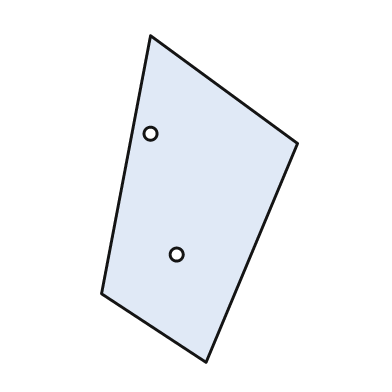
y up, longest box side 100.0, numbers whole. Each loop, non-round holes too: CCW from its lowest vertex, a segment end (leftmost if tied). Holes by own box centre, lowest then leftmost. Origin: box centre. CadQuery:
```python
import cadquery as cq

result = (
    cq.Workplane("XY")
    .moveTo(2.0, -50.0)
    .lineTo(30.0, 17.0)
    .lineTo(-15.0, 50.0)
    .lineTo(-30.0, -29.0)
    .close()
    .moveTo(-7.0, -17.0)
    .circle(2.0)
    .moveTo(-15.0, 20.0)
    .circle(2.0)
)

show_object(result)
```